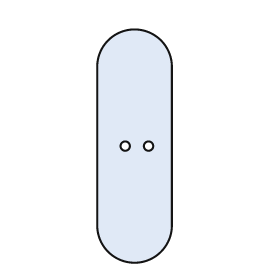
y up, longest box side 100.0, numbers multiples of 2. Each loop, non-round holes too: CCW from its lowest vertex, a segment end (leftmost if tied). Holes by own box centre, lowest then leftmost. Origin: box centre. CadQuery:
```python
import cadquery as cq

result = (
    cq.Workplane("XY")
    .moveTo(-16.0, -34.0)
    .threePointArc((0.0, -50.0), (16.0, -34.0))
    .lineTo(16.0, 34.0)
    .threePointArc((0.0, 50.0), (-16.0, 34.0))
    .close()
    .moveTo(-4.0, 0.0)
    .circle(2.0)
    .moveTo(6.0, 0.0)
    .circle(2.0)
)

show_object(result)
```